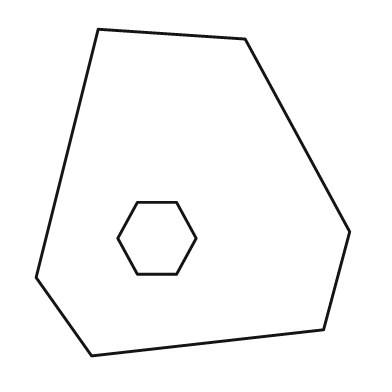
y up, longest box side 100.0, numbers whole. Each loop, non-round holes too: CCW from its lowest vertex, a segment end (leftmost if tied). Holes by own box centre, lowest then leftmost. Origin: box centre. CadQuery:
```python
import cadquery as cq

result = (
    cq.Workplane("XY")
    .moveTo(-31.0, -50.0)
    .lineTo(40.0, -42.0)
    .lineTo(48.0, -12.0)
    .lineTo(16.0, 47.0)
    .lineTo(-29.0, 50.0)
    .lineTo(-48.0, -26.0)
    .close()
    .moveTo(-17.0, -25.0)
    .lineTo(-5.0, -25.0)
    .lineTo(1.0, -14.0)
    .lineTo(-5.0, -3.0)
    .lineTo(-17.0, -3.0)
    .lineTo(-23.0, -14.0)
    .close()
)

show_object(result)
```